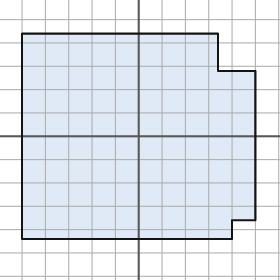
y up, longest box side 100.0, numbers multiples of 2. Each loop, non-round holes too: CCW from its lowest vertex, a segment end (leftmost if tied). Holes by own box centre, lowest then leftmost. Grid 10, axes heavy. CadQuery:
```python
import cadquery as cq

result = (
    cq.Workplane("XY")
    .moveTo(-50.0, -44.0)
    .lineTo(40.0, -44.0)
    .lineTo(40.0, -36.0)
    .lineTo(50.0, -36.0)
    .lineTo(50.0, 28.0)
    .lineTo(34.0, 28.0)
    .lineTo(34.0, 44.0)
    .lineTo(-50.0, 44.0)
    .close()
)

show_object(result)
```